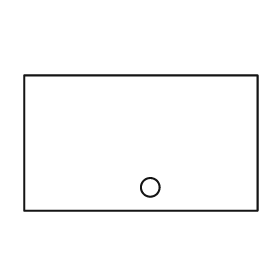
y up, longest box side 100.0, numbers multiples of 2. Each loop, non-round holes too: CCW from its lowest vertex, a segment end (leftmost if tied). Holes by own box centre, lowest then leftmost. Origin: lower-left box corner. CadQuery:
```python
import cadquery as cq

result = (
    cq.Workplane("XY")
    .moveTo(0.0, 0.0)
    .lineTo(100.0, 0.0)
    .lineTo(100.0, 58.0)
    .lineTo(0.0, 58.0)
    .close()
    .moveTo(54.0, 10.0)
    .circle(4.0)
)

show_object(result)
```